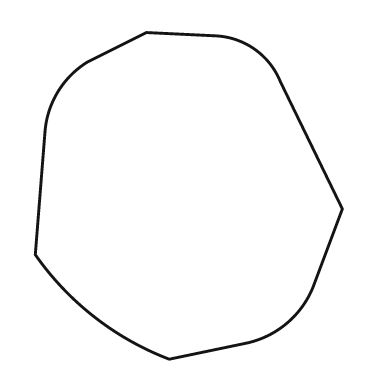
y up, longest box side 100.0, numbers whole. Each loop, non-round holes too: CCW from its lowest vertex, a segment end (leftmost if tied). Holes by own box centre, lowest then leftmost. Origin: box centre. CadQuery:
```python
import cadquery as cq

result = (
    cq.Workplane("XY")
    .moveTo(-6.0, -50.0)
    .lineTo(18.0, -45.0)
    .threePointArc((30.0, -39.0), (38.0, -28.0))
    .lineTo(47.0, -4.0)
    .lineTo(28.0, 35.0)
    .threePointArc((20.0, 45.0), (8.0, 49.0))
    .lineTo(-13.0, 50.0)
    .lineTo(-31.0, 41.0)
    .threePointArc((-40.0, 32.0), (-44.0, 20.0))
    .lineTo(-47.0, -18.0)
    .threePointArc((-29.0, -37.0), (-6.0, -50.0))
    .close()
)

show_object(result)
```